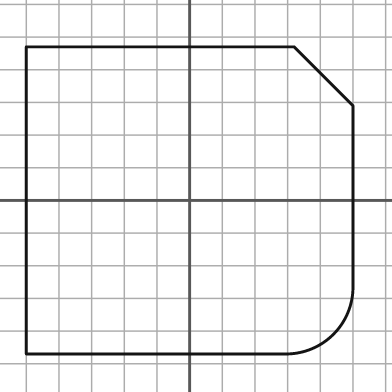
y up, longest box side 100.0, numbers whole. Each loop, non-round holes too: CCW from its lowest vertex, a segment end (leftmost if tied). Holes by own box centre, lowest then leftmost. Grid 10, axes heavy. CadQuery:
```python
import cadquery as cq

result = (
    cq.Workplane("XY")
    .moveTo(-50.0, -47.0)
    .lineTo(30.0, -47.0)
    .threePointArc((44.0, -41.0), (50.0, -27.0))
    .lineTo(50.0, 29.0)
    .lineTo(32.0, 47.0)
    .lineTo(-50.0, 47.0)
    .close()
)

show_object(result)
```